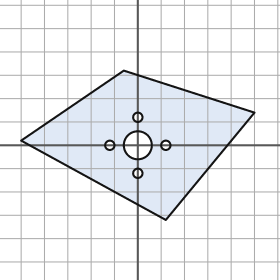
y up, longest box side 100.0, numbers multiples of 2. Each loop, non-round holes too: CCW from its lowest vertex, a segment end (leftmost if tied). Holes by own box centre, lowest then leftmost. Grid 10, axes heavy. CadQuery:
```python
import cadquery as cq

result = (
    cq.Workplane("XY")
    .moveTo(12.0, -32.0)
    .lineTo(50.0, 14.0)
    .lineTo(-6.0, 32.0)
    .lineTo(-50.0, 2.0)
    .close()
    .moveTo(0.0, -12.0)
    .circle(2.0)
    .moveTo(-12.0, 0.0)
    .circle(2.0)
    .moveTo(0.0, 0.0)
    .circle(6.0)
    .moveTo(12.0, 0.0)
    .circle(2.0)
    .moveTo(0.0, 12.0)
    .circle(2.0)
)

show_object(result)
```